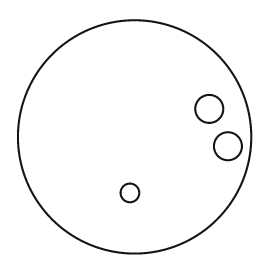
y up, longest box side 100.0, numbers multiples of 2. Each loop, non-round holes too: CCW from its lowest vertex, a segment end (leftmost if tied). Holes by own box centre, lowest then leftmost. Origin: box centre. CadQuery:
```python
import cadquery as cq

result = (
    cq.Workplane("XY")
    .moveTo(0.0, 0.0)
    .circle(50.0)
    .moveTo(-2.0, -24.0)
    .circle(4.0)
    .moveTo(40.0, -4.0)
    .circle(6.0)
    .moveTo(32.0, 12.0)
    .circle(6.0)
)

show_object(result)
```